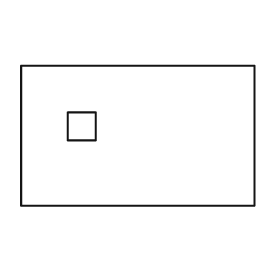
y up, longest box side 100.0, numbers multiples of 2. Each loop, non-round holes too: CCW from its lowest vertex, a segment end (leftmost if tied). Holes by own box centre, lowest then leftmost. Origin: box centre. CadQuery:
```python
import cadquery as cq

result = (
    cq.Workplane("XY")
    .moveTo(-50.0, -30.0)
    .lineTo(50.0, -30.0)
    .lineTo(50.0, 30.0)
    .lineTo(-50.0, 30.0)
    .close()
    .moveTo(-30.0, -2.0)
    .lineTo(-18.0, -2.0)
    .lineTo(-18.0, 10.0)
    .lineTo(-30.0, 10.0)
    .close()
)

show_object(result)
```